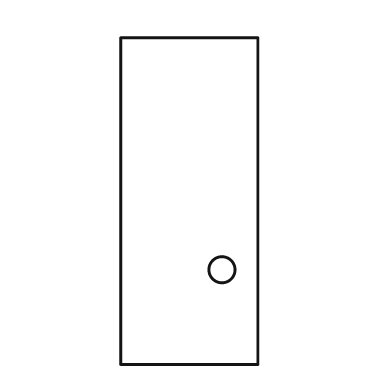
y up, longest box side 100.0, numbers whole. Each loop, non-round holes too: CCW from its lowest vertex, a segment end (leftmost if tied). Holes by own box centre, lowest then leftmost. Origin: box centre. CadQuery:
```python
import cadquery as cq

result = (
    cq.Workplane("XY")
    .moveTo(-21.0, -50.0)
    .lineTo(21.0, -50.0)
    .lineTo(21.0, 50.0)
    .lineTo(-21.0, 50.0)
    .close()
    .moveTo(10.0, -21.0)
    .circle(4.0)
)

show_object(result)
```